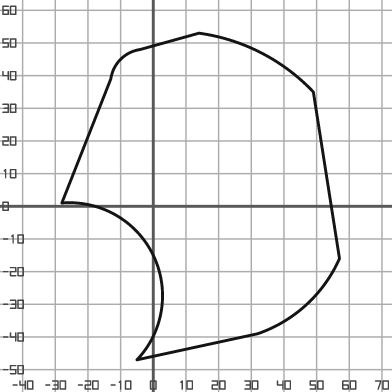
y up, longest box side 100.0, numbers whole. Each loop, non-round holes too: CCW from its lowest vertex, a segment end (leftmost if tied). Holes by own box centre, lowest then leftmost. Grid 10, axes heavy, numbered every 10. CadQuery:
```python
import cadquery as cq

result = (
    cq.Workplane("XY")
    .moveTo(-5.0, -47.0)
    .lineTo(32.0, -39.0)
    .threePointArc((47.0, -30.0), (57.0, -16.0))
    .lineTo(49.0, 35.0)
    .threePointArc((33.0, 47.0), (14.0, 53.0))
    .lineTo(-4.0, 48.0)
    .threePointArc((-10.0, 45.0), (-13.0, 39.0))
    .lineTo(-28.0, 1.0)
    .threePointArc((0.0, -15.0), (-5.0, -47.0))
    .close()
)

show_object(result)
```